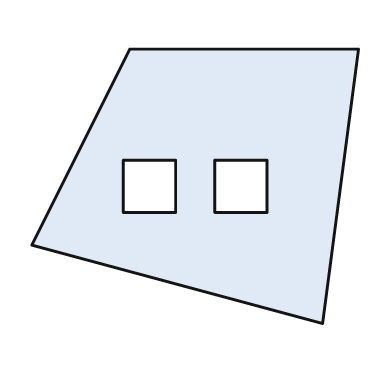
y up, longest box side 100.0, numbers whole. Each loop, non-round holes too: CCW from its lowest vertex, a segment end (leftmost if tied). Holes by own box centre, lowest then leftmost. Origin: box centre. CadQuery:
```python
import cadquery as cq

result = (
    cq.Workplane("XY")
    .moveTo(39.0, -42.0)
    .lineTo(50.0, 42.0)
    .lineTo(-20.0, 42.0)
    .lineTo(-50.0, -18.0)
    .close()
    .moveTo(-22.0, -8.0)
    .lineTo(-6.0, -8.0)
    .lineTo(-6.0, 8.0)
    .lineTo(-22.0, 8.0)
    .close()
    .moveTo(6.0, -8.0)
    .lineTo(22.0, -8.0)
    .lineTo(22.0, 8.0)
    .lineTo(6.0, 8.0)
    .close()
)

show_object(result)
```